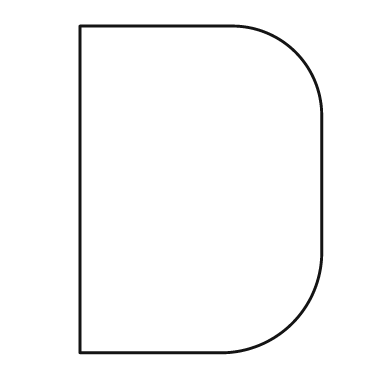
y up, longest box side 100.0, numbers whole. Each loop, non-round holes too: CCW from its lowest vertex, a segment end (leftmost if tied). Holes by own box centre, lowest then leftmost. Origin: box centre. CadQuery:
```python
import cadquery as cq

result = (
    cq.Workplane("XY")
    .moveTo(-37.0, -50.0)
    .lineTo(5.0, -50.0)
    .threePointArc((28.0, -41.0), (37.0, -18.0))
    .lineTo(37.0, 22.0)
    .threePointArc((29.0, 42.0), (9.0, 50.0))
    .lineTo(-37.0, 50.0)
    .close()
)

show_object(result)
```